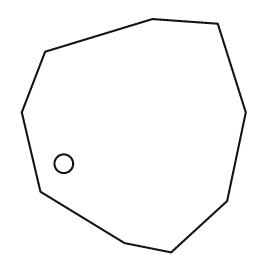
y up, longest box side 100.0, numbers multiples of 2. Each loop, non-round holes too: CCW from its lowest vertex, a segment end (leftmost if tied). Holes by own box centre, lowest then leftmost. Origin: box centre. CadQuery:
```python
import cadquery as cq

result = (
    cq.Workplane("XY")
    .moveTo(16.0, -50.0)
    .lineTo(40.0, -28.0)
    .lineTo(48.0, 10.0)
    .lineTo(36.0, 48.0)
    .lineTo(8.0, 50.0)
    .lineTo(-38.0, 36.0)
    .lineTo(-48.0, 10.0)
    .lineTo(-40.0, -24.0)
    .lineTo(-4.0, -46.0)
    .close()
    .moveTo(-30.0, -12.0)
    .circle(4.0)
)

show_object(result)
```